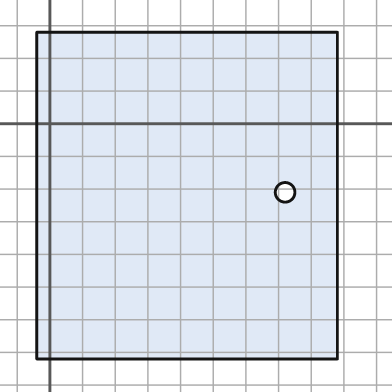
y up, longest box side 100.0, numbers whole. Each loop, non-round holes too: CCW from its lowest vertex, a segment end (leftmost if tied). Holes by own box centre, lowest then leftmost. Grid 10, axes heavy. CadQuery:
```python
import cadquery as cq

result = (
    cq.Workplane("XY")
    .moveTo(-4.0, -72.0)
    .lineTo(88.0, -72.0)
    .lineTo(88.0, 28.0)
    .lineTo(-4.0, 28.0)
    .close()
    .moveTo(72.0, -21.0)
    .circle(3.0)
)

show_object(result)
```